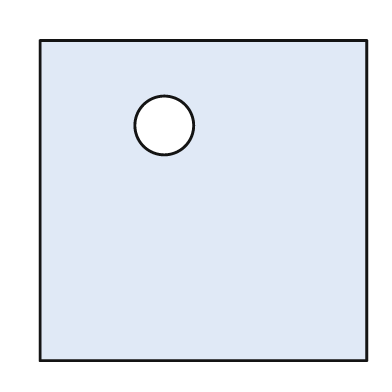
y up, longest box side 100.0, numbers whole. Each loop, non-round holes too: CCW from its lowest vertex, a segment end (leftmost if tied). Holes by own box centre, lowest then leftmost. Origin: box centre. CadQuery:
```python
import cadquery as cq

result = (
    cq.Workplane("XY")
    .moveTo(-50.0, -49.0)
    .lineTo(50.0, -49.0)
    .lineTo(50.0, 49.0)
    .lineTo(-50.0, 49.0)
    .close()
    .moveTo(-12.0, 23.0)
    .circle(9.0)
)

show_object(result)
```